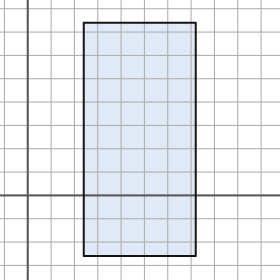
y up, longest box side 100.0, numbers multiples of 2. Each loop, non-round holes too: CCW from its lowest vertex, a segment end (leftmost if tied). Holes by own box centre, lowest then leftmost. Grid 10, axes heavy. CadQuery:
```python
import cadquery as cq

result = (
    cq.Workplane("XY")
    .moveTo(24.0, -26.0)
    .lineTo(72.0, -26.0)
    .lineTo(72.0, 74.0)
    .lineTo(24.0, 74.0)
    .close()
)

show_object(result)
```